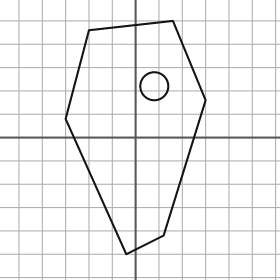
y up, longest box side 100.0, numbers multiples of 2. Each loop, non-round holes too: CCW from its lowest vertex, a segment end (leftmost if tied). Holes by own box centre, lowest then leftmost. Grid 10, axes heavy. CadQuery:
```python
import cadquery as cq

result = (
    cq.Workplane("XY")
    .moveTo(-4.0, -50.0)
    .lineTo(12.0, -42.0)
    .lineTo(30.0, 16.0)
    .lineTo(16.0, 50.0)
    .lineTo(-20.0, 46.0)
    .lineTo(-30.0, 8.0)
    .close()
    .moveTo(8.0, 22.0)
    .circle(6.0)
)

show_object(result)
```